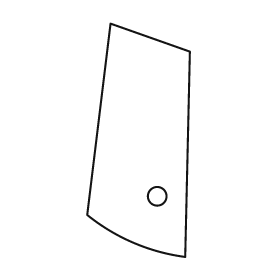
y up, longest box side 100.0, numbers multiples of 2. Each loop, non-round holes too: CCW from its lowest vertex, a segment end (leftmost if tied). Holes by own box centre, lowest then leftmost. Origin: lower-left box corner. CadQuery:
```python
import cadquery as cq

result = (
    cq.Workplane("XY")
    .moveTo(42.0, 0.0)
    .lineTo(44.0, 88.0)
    .lineTo(10.0, 100.0)
    .lineTo(0.0, 18.0)
    .threePointArc((20.0, 6.0), (42.0, 0.0))
    .close()
    .moveTo(30.0, 26.0)
    .circle(4.0)
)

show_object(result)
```